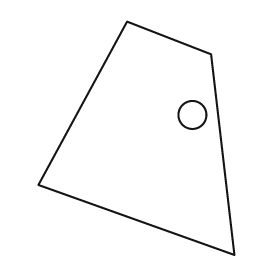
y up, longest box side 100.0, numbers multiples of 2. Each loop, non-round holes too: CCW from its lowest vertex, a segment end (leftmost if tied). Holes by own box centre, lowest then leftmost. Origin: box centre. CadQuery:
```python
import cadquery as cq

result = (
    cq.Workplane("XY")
    .moveTo(42.0, -50.0)
    .lineTo(32.0, 36.0)
    .lineTo(-4.0, 50.0)
    .lineTo(-42.0, -20.0)
    .close()
    .moveTo(24.0, 10.0)
    .circle(6.0)
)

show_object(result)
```